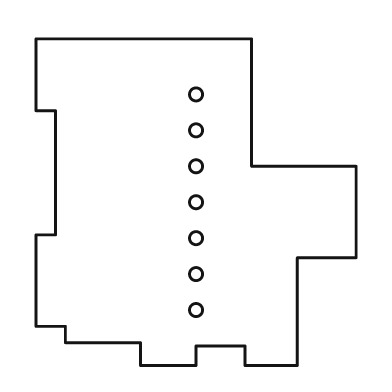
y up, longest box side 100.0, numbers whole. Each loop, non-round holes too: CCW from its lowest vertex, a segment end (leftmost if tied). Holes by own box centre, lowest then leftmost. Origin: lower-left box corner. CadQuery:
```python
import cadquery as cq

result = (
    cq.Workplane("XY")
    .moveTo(32.0, 0.0)
    .lineTo(49.0, 0.0)
    .lineTo(49.0, 6.0)
    .lineTo(64.0, 6.0)
    .lineTo(64.0, 0.0)
    .lineTo(80.0, 0.0)
    .lineTo(80.0, 33.0)
    .lineTo(98.0, 33.0)
    .lineTo(98.0, 61.0)
    .lineTo(66.0, 61.0)
    .lineTo(66.0, 100.0)
    .lineTo(0.0, 100.0)
    .lineTo(0.0, 78.0)
    .lineTo(6.0, 78.0)
    .lineTo(6.0, 40.0)
    .lineTo(0.0, 40.0)
    .lineTo(0.0, 12.0)
    .lineTo(9.0, 12.0)
    .lineTo(9.0, 7.0)
    .lineTo(32.0, 7.0)
    .close()
    .moveTo(49.0, 17.0)
    .circle(2.0)
    .moveTo(49.0, 28.0)
    .circle(2.0)
    .moveTo(49.0, 39.0)
    .circle(2.0)
    .moveTo(49.0, 50.0)
    .circle(2.0)
    .moveTo(49.0, 61.0)
    .circle(2.0)
    .moveTo(49.0, 72.0)
    .circle(2.0)
    .moveTo(49.0, 83.0)
    .circle(2.0)
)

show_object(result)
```